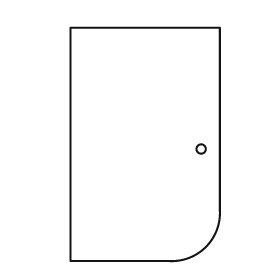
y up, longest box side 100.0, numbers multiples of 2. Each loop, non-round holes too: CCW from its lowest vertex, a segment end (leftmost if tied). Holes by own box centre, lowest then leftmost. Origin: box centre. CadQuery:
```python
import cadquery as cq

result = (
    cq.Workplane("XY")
    .moveTo(-32.0, -50.0)
    .lineTo(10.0, -50.0)
    .threePointArc((26.0, -44.0), (32.0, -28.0))
    .lineTo(32.0, 50.0)
    .lineTo(-32.0, 50.0)
    .close()
    .moveTo(24.0, -2.0)
    .circle(2.0)
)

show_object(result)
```